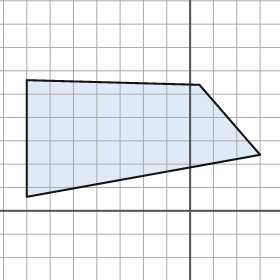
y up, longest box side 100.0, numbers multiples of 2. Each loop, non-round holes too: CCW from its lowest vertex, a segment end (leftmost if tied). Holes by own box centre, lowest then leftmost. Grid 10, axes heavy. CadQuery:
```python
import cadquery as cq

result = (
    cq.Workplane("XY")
    .moveTo(-70.0, 6.0)
    .lineTo(30.0, 24.0)
    .lineTo(4.0, 54.0)
    .lineTo(-70.0, 56.0)
    .close()
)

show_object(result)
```